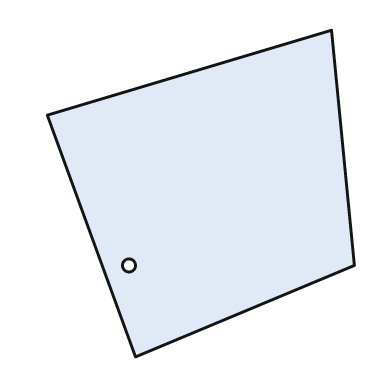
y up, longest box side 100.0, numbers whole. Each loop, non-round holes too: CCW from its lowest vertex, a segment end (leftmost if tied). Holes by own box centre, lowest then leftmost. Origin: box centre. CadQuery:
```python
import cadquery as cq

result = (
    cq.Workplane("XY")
    .moveTo(-20.0, -50.0)
    .lineTo(47.0, -22.0)
    .lineTo(40.0, 50.0)
    .lineTo(-47.0, 24.0)
    .close()
    .moveTo(-22.0, -22.0)
    .circle(2.0)
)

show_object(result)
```